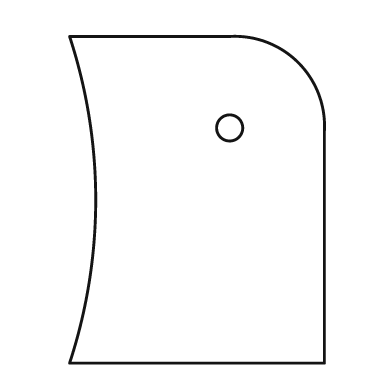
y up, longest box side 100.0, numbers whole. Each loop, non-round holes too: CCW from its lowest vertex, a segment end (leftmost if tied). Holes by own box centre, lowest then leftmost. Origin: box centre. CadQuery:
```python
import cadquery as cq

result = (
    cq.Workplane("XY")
    .moveTo(-39.0, -50.0)
    .lineTo(39.0, -50.0)
    .lineTo(39.0, 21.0)
    .threePointArc((31.0, 42.0), (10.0, 50.0))
    .lineTo(-39.0, 50.0)
    .threePointArc((-31.0, 0.0), (-39.0, -50.0))
    .close()
    .moveTo(10.0, 22.0)
    .circle(4.0)
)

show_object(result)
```